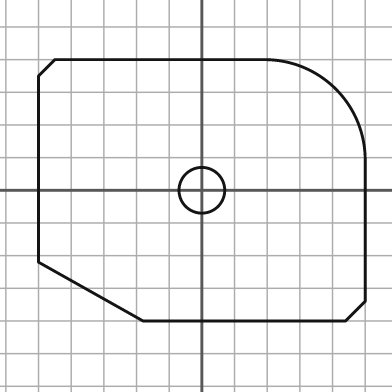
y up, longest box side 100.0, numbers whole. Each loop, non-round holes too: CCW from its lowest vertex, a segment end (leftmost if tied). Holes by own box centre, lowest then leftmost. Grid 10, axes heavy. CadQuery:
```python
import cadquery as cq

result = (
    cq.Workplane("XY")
    .moveTo(-18.0, -40.0)
    .lineTo(44.0, -40.0)
    .lineTo(50.0, -34.0)
    .lineTo(50.0, 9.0)
    .threePointArc((41.0, 31.0), (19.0, 40.0))
    .lineTo(-45.0, 40.0)
    .lineTo(-50.0, 35.0)
    .lineTo(-50.0, -22.0)
    .close()
    .moveTo(0.0, 0.0)
    .circle(7.0)
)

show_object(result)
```